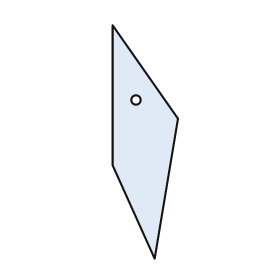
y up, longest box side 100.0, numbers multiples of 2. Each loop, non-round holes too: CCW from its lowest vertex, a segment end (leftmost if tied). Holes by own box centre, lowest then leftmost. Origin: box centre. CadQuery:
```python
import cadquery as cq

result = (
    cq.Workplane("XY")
    .moveTo(4.0, -50.0)
    .lineTo(14.0, 10.0)
    .lineTo(-14.0, 50.0)
    .lineTo(-14.0, -10.0)
    .close()
    .moveTo(-4.0, 18.0)
    .circle(2.0)
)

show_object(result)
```